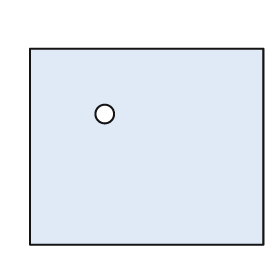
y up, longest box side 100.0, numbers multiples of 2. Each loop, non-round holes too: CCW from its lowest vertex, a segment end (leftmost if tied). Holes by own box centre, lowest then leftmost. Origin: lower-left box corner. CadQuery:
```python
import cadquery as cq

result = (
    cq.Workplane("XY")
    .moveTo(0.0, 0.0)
    .lineTo(100.0, 0.0)
    .lineTo(100.0, 84.0)
    .lineTo(0.0, 84.0)
    .close()
    .moveTo(32.0, 56.0)
    .circle(4.0)
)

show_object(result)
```